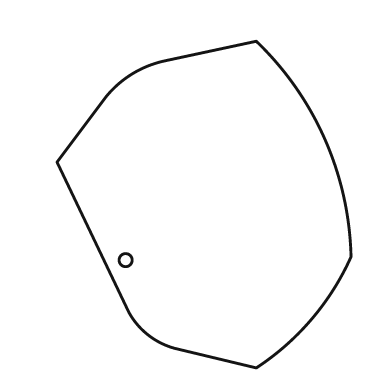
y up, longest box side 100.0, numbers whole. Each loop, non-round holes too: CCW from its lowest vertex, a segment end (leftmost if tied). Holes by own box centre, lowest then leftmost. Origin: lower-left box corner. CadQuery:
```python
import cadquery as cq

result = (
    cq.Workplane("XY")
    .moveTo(61.0, 0.0)
    .threePointArc((78.0, 15.0), (90.0, 34.0))
    .threePointArc((82.0, 70.0), (61.0, 100.0))
    .lineTo(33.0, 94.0)
    .threePointArc((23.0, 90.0), (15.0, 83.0))
    .lineTo(0.0, 63.0)
    .lineTo(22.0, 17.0)
    .threePointArc((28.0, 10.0), (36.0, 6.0))
    .close()
    .moveTo(21.0, 33.0)
    .circle(2.0)
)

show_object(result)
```